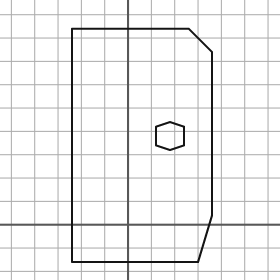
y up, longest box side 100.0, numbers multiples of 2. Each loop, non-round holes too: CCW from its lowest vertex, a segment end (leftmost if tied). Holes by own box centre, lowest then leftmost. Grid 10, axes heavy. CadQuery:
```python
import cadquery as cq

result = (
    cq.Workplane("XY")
    .moveTo(-24.0, -16.0)
    .lineTo(30.0, -16.0)
    .lineTo(36.0, 4.0)
    .lineTo(36.0, 74.0)
    .lineTo(26.0, 84.0)
    .lineTo(-24.0, 84.0)
    .close()
    .moveTo(18.0, 32.0)
    .lineTo(24.0, 34.0)
    .lineTo(24.0, 42.0)
    .lineTo(18.0, 44.0)
    .lineTo(12.0, 42.0)
    .lineTo(12.0, 34.0)
    .close()
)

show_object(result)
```